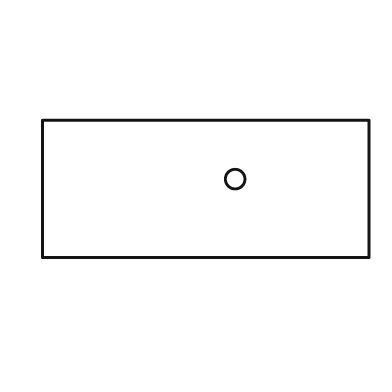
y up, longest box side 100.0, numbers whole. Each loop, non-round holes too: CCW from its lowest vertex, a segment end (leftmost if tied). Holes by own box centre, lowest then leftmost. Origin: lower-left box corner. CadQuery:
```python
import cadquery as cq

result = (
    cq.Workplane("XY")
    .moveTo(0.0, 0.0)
    .lineTo(100.0, 0.0)
    .lineTo(100.0, 42.0)
    .lineTo(0.0, 42.0)
    .close()
    .moveTo(59.0, 24.0)
    .circle(3.0)
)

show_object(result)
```